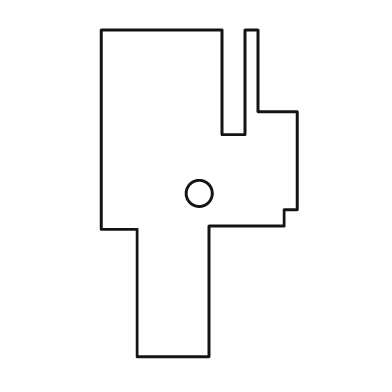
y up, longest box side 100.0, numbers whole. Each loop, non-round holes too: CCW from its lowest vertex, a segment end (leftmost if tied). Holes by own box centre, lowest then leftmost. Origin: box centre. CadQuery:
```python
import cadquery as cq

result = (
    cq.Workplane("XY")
    .moveTo(-19.0, -50.0)
    .lineTo(3.0, -50.0)
    .lineTo(3.0, -10.0)
    .lineTo(26.0, -10.0)
    .lineTo(26.0, -5.0)
    .lineTo(30.0, -5.0)
    .lineTo(30.0, 25.0)
    .lineTo(18.0, 25.0)
    .lineTo(18.0, 50.0)
    .lineTo(14.0, 50.0)
    .lineTo(14.0, 18.0)
    .lineTo(7.0, 18.0)
    .lineTo(7.0, 50.0)
    .lineTo(-30.0, 50.0)
    .lineTo(-30.0, -11.0)
    .lineTo(-19.0, -11.0)
    .close()
    .moveTo(0.0, 0.0)
    .circle(4.0)
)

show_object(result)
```